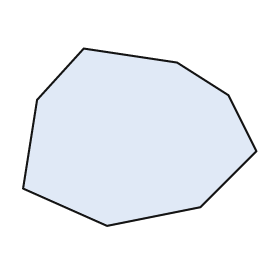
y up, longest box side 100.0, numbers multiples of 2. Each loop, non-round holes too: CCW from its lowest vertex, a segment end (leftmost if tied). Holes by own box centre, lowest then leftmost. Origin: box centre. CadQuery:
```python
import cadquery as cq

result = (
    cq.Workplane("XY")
    .moveTo(-14.0, -38.0)
    .lineTo(26.0, -30.0)
    .lineTo(50.0, -6.0)
    .lineTo(38.0, 18.0)
    .lineTo(16.0, 32.0)
    .lineTo(-24.0, 38.0)
    .lineTo(-44.0, 16.0)
    .lineTo(-50.0, -22.0)
    .close()
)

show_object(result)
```